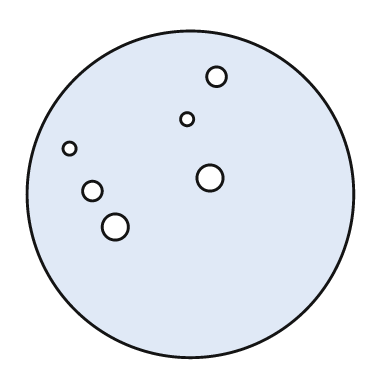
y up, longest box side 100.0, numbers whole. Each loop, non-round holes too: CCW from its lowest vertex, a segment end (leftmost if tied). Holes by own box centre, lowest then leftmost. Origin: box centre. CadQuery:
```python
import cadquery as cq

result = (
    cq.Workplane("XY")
    .moveTo(0.0, 0.0)
    .circle(50.0)
    .moveTo(-23.0, -10.0)
    .circle(4.0)
    .moveTo(-30.0, 1.0)
    .circle(3.0)
    .moveTo(6.0, 5.0)
    .circle(4.0)
    .moveTo(-37.0, 14.0)
    .circle(2.0)
    .moveTo(-1.0, 23.0)
    .circle(2.0)
    .moveTo(8.0, 36.0)
    .circle(3.0)
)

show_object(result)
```